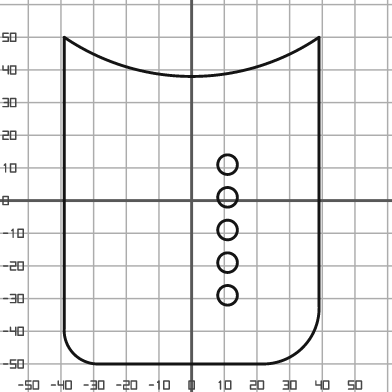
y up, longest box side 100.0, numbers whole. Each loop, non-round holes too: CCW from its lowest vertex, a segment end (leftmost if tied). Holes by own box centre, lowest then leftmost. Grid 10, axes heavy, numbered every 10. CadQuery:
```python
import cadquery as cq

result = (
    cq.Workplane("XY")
    .moveTo(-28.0, -50.0)
    .lineTo(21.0, -50.0)
    .threePointArc((34.0, -45.0), (39.0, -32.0))
    .lineTo(39.0, 50.0)
    .threePointArc((0.0, 38.0), (-39.0, 50.0))
    .lineTo(-39.0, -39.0)
    .threePointArc((-36.0, -47.0), (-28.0, -50.0))
    .close()
    .moveTo(11.0, -29.0)
    .circle(3.0)
    .moveTo(11.0, -19.0)
    .circle(3.0)
    .moveTo(11.0, -9.0)
    .circle(3.0)
    .moveTo(11.0, 1.0)
    .circle(3.0)
    .moveTo(11.0, 11.0)
    .circle(3.0)
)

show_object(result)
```